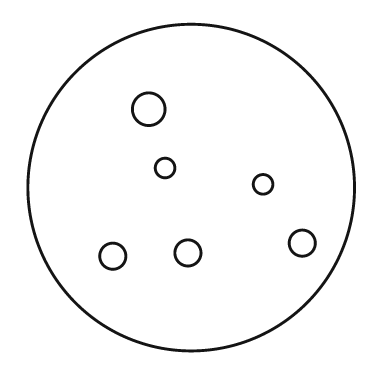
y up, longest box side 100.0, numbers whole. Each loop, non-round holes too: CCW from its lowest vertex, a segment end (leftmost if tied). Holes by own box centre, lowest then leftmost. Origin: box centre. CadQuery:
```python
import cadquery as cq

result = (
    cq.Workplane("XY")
    .moveTo(0.0, 0.0)
    .circle(50.0)
    .moveTo(-24.0, -21.0)
    .circle(4.0)
    .moveTo(-1.0, -20.0)
    .circle(4.0)
    .moveTo(34.0, -17.0)
    .circle(4.0)
    .moveTo(22.0, 1.0)
    .circle(3.0)
    .moveTo(-8.0, 6.0)
    .circle(3.0)
    .moveTo(-13.0, 24.0)
    .circle(5.0)
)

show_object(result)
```